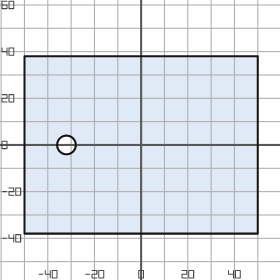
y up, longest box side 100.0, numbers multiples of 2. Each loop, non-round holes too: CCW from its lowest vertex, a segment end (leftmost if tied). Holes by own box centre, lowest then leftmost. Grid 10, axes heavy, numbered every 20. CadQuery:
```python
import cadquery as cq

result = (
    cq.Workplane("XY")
    .moveTo(-50.0, -38.0)
    .lineTo(50.0, -38.0)
    .lineTo(50.0, 38.0)
    .lineTo(-50.0, 38.0)
    .close()
    .moveTo(-32.0, 0.0)
    .circle(4.0)
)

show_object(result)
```